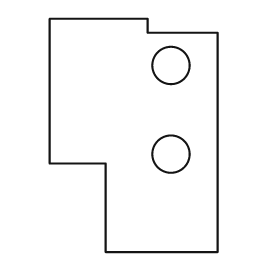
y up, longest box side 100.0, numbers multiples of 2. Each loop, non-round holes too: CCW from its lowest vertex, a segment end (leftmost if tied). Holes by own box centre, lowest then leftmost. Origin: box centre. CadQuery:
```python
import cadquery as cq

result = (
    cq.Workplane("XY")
    .moveTo(-12.0, -50.0)
    .lineTo(36.0, -50.0)
    .lineTo(36.0, 44.0)
    .lineTo(6.0, 44.0)
    .lineTo(6.0, 50.0)
    .lineTo(-36.0, 50.0)
    .lineTo(-36.0, -12.0)
    .lineTo(-12.0, -12.0)
    .close()
    .moveTo(16.0, -8.0)
    .circle(8.0)
    .moveTo(16.0, 30.0)
    .circle(8.0)
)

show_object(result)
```